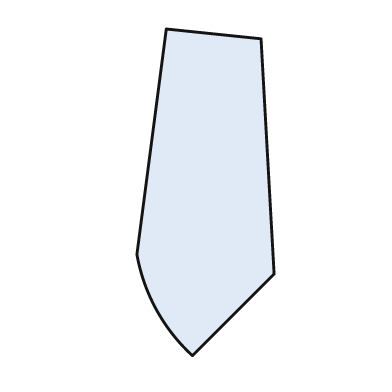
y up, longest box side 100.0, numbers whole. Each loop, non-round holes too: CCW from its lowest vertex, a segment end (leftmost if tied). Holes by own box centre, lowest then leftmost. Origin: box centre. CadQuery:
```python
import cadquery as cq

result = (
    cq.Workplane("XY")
    .moveTo(-4.0, -50.0)
    .lineTo(21.0, -25.0)
    .lineTo(17.0, 47.0)
    .lineTo(-12.0, 50.0)
    .lineTo(-21.0, -19.0)
    .threePointArc((-15.0, -36.0), (-4.0, -50.0))
    .close()
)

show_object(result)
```